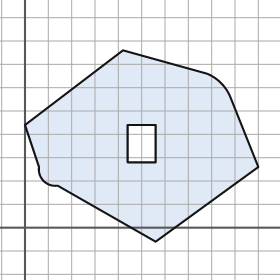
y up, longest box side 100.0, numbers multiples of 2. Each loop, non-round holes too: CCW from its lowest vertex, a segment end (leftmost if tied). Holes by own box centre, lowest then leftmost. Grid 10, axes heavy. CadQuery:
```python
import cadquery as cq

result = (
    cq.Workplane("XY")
    .moveTo(56.0, -6.0)
    .lineTo(100.0, 26.0)
    .lineTo(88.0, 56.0)
    .threePointArc((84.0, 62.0), (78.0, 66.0))
    .lineTo(42.0, 76.0)
    .lineTo(0.0, 44.0)
    .lineTo(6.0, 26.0)
    .threePointArc((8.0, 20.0), (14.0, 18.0))
    .close()
    .moveTo(44.0, 28.0)
    .lineTo(56.0, 28.0)
    .lineTo(56.0, 44.0)
    .lineTo(44.0, 44.0)
    .close()
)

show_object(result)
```